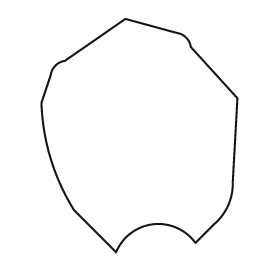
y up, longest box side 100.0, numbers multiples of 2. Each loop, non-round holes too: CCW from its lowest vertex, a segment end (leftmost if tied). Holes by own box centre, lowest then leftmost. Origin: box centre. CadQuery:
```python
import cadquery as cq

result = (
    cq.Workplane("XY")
    .moveTo(-10.0, -50.0)
    .threePointArc((6.0, -38.0), (24.0, -46.0))
    .lineTo(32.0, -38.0)
    .threePointArc((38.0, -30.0), (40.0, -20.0))
    .lineTo(42.0, 16.0)
    .lineTo(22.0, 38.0)
    .threePointArc((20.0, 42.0), (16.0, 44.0))
    .lineTo(-6.0, 50.0)
    .lineTo(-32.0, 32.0)
    .threePointArc((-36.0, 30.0), (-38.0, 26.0))
    .lineTo(-42.0, 14.0)
    .threePointArc((-38.0, -10.0), (-28.0, -32.0))
    .close()
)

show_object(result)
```